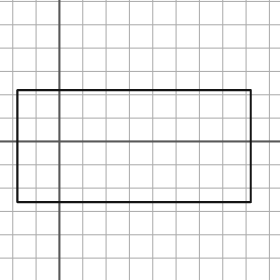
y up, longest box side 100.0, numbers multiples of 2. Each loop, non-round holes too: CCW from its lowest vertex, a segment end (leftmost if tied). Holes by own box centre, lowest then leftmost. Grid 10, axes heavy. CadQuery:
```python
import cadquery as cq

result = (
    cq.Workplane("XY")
    .moveTo(-18.0, -26.0)
    .lineTo(82.0, -26.0)
    .lineTo(82.0, 22.0)
    .lineTo(-18.0, 22.0)
    .close()
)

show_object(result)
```